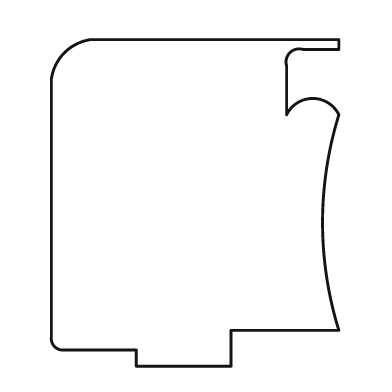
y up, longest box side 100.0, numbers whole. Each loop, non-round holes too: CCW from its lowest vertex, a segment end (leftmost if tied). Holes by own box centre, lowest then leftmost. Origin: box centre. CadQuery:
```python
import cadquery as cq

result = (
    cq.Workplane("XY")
    .moveTo(-18.0, -50.0)
    .lineTo(11.0, -50.0)
    .lineTo(11.0, -39.0)
    .lineTo(44.0, -39.0)
    .threePointArc((39.0, -6.0), (44.0, 27.0))
    .threePointArc((36.0, 32.0), (28.0, 27.0))
    .lineTo(28.0, 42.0)
    .threePointArc((29.0, 46.0), (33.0, 47.0))
    .lineTo(44.0, 47.0)
    .lineTo(44.0, 50.0)
    .lineTo(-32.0, 50.0)
    .threePointArc((-40.0, 46.0), (-44.0, 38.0))
    .lineTo(-44.0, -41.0)
    .threePointArc((-43.0, -44.0), (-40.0, -45.0))
    .lineTo(-18.0, -45.0)
    .close()
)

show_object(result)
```